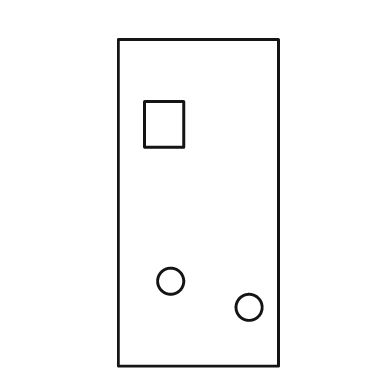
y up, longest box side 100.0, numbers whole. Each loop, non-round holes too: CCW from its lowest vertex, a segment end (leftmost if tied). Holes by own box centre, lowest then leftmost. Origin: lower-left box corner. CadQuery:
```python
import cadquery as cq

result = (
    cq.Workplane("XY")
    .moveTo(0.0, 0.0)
    .lineTo(49.0, 0.0)
    .lineTo(49.0, 100.0)
    .lineTo(0.0, 100.0)
    .close()
    .moveTo(40.0, 18.0)
    .circle(4.0)
    .moveTo(16.0, 26.0)
    .circle(4.0)
    .moveTo(8.0, 67.0)
    .lineTo(20.0, 67.0)
    .lineTo(20.0, 81.0)
    .lineTo(8.0, 81.0)
    .close()
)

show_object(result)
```